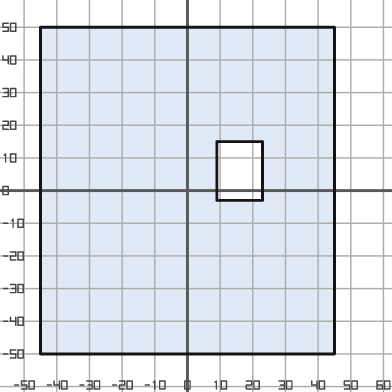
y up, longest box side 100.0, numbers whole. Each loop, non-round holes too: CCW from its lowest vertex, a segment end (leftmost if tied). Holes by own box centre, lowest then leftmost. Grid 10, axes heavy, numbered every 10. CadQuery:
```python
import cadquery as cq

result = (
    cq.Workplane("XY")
    .moveTo(-45.0, -50.0)
    .lineTo(45.0, -50.0)
    .lineTo(45.0, 50.0)
    .lineTo(-45.0, 50.0)
    .close()
    .moveTo(9.0, -3.0)
    .lineTo(23.0, -3.0)
    .lineTo(23.0, 15.0)
    .lineTo(9.0, 15.0)
    .close()
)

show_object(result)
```